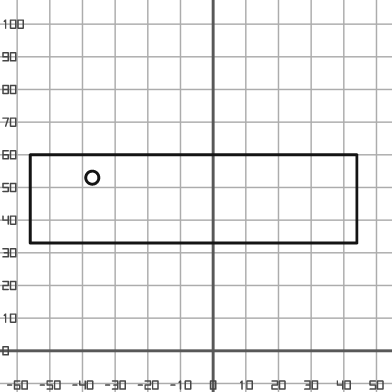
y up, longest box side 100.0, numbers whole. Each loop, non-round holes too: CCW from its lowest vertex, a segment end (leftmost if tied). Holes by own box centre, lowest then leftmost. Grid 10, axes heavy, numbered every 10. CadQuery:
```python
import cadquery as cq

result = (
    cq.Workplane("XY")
    .moveTo(-56.0, 33.0)
    .lineTo(44.0, 33.0)
    .lineTo(44.0, 60.0)
    .lineTo(-56.0, 60.0)
    .close()
    .moveTo(-37.0, 53.0)
    .circle(2.0)
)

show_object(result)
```